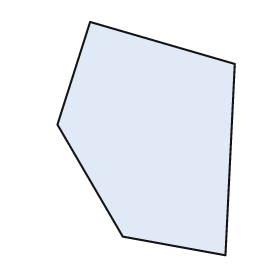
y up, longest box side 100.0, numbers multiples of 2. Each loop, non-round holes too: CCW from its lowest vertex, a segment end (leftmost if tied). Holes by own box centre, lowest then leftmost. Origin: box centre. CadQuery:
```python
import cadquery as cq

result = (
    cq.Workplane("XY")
    .moveTo(34.0, -50.0)
    .lineTo(38.0, 32.0)
    .lineTo(-24.0, 50.0)
    .lineTo(-38.0, 6.0)
    .lineTo(-10.0, -42.0)
    .close()
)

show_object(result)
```